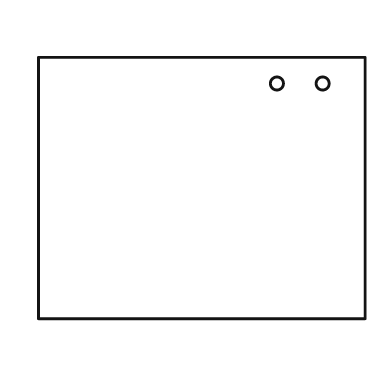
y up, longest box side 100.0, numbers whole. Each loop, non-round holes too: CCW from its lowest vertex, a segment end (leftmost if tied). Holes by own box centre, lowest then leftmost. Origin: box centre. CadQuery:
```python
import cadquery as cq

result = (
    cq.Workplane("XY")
    .moveTo(-50.0, -40.0)
    .lineTo(50.0, -40.0)
    .lineTo(50.0, 40.0)
    .lineTo(-50.0, 40.0)
    .close()
    .moveTo(23.0, 32.0)
    .circle(2.0)
    .moveTo(37.0, 32.0)
    .circle(2.0)
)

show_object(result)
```